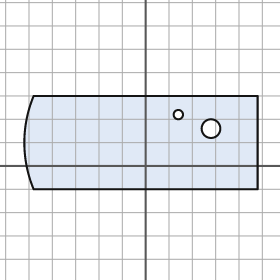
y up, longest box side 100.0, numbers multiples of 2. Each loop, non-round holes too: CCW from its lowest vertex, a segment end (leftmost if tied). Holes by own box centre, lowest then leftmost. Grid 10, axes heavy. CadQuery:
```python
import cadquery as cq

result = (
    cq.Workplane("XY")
    .moveTo(-48.0, -10.0)
    .lineTo(48.0, -10.0)
    .lineTo(48.0, 30.0)
    .lineTo(-48.0, 30.0)
    .threePointArc((-52.0, 10.0), (-48.0, -10.0))
    .close()
    .moveTo(28.0, 16.0)
    .circle(4.0)
    .moveTo(14.0, 22.0)
    .circle(2.0)
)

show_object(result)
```